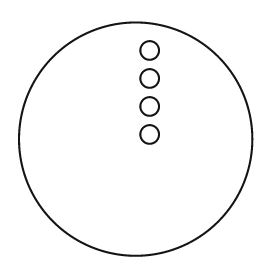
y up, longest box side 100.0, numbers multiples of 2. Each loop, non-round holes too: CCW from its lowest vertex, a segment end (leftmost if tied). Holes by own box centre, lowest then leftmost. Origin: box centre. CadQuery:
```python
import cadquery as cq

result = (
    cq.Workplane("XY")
    .moveTo(0.0, 0.0)
    .circle(50.0)
    .moveTo(6.0, 2.0)
    .circle(4.0)
    .moveTo(6.0, 14.0)
    .circle(4.0)
    .moveTo(6.0, 26.0)
    .circle(4.0)
    .moveTo(6.0, 38.0)
    .circle(4.0)
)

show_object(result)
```